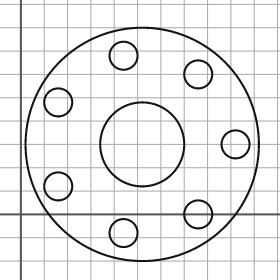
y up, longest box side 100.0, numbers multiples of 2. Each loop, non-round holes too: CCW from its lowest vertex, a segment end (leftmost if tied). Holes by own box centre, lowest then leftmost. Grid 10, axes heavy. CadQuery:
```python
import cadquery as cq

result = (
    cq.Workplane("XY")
    .moveTo(52.0, 30.0)
    .circle(50.0)
    .moveTo(44.0, -8.0)
    .circle(6.0)
    .moveTo(76.0, 0.0)
    .circle(6.0)
    .moveTo(16.0, 12.0)
    .circle(6.0)
    .moveTo(52.0, 30.0)
    .circle(18.0)
    .moveTo(92.0, 30.0)
    .circle(6.0)
    .moveTo(16.0, 48.0)
    .circle(6.0)
    .moveTo(76.0, 60.0)
    .circle(6.0)
    .moveTo(44.0, 68.0)
    .circle(6.0)
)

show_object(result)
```